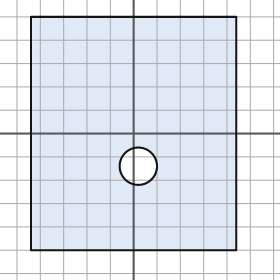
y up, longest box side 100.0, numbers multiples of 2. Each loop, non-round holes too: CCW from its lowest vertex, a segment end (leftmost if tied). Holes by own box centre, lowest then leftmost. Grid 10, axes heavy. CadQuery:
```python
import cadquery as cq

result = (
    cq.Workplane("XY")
    .moveTo(-44.0, -50.0)
    .lineTo(44.0, -50.0)
    .lineTo(44.0, 50.0)
    .lineTo(-44.0, 50.0)
    .close()
    .moveTo(2.0, -14.0)
    .circle(8.0)
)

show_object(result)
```